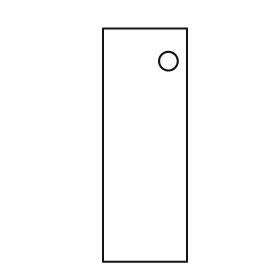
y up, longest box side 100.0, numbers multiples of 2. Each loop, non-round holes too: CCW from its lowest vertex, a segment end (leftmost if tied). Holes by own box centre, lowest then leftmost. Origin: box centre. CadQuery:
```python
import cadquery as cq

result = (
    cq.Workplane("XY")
    .moveTo(-18.0, -50.0)
    .lineTo(18.0, -50.0)
    .lineTo(18.0, 50.0)
    .lineTo(-18.0, 50.0)
    .close()
    .moveTo(10.0, 36.0)
    .circle(4.0)
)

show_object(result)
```